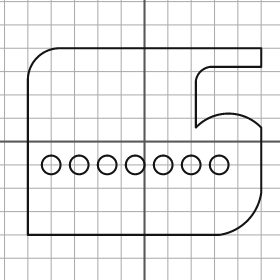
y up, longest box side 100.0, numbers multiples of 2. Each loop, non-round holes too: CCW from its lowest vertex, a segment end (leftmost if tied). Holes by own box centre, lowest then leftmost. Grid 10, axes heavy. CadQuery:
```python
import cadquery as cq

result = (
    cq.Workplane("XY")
    .moveTo(-50.0, -40.0)
    .lineTo(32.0, -40.0)
    .threePointArc((44.0, -34.0), (50.0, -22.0))
    .lineTo(50.0, 6.0)
    .threePointArc((36.0, 12.0), (22.0, 6.0))
    .lineTo(22.0, 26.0)
    .threePointArc((24.0, 30.0), (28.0, 32.0))
    .lineTo(50.0, 32.0)
    .lineTo(50.0, 40.0)
    .lineTo(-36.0, 40.0)
    .threePointArc((-46.0, 36.0), (-50.0, 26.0))
    .close()
    .moveTo(-40.0, -10.0)
    .circle(4.0)
    .moveTo(-28.0, -10.0)
    .circle(4.0)
    .moveTo(-16.0, -10.0)
    .circle(4.0)
    .moveTo(-4.0, -10.0)
    .circle(4.0)
    .moveTo(8.0, -10.0)
    .circle(4.0)
    .moveTo(20.0, -10.0)
    .circle(4.0)
    .moveTo(32.0, -10.0)
    .circle(4.0)
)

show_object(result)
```